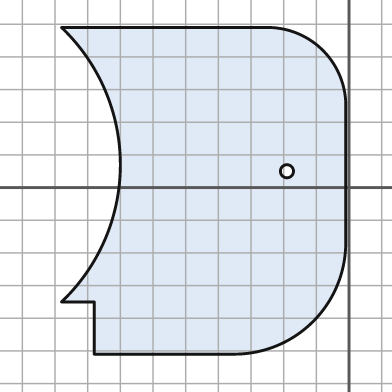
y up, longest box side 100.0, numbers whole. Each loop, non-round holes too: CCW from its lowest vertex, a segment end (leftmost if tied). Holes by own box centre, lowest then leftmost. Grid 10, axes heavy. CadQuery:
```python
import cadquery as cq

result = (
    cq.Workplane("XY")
    .moveTo(-78.0, -51.0)
    .lineTo(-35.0, -51.0)
    .threePointArc((-11.0, -41.0), (-1.0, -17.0))
    .lineTo(-1.0, 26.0)
    .threePointArc((-8.0, 42.0), (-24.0, 49.0))
    .lineTo(-88.0, 49.0)
    .threePointArc((-70.0, 7.0), (-88.0, -35.0))
    .lineTo(-78.0, -35.0)
    .close()
    .moveTo(-19.0, 5.0)
    .circle(2.0)
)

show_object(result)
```